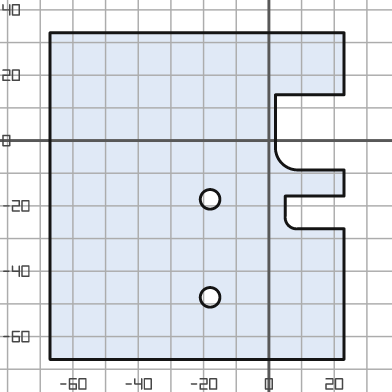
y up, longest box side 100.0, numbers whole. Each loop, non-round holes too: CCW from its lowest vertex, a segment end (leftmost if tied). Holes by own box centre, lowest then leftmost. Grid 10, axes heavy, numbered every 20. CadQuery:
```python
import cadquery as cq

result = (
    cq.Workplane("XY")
    .moveTo(-67.0, -67.0)
    .lineTo(23.0, -67.0)
    .lineTo(23.0, -27.0)
    .lineTo(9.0, -27.0)
    .threePointArc((6.0, -26.0), (5.0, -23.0))
    .lineTo(5.0, -17.0)
    .lineTo(23.0, -17.0)
    .lineTo(23.0, -9.0)
    .lineTo(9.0, -9.0)
    .threePointArc((4.0, -7.0), (2.0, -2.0))
    .lineTo(2.0, 14.0)
    .lineTo(23.0, 14.0)
    .lineTo(23.0, 33.0)
    .lineTo(-67.0, 33.0)
    .close()
    .moveTo(-18.0, -48.0)
    .circle(3.0)
    .moveTo(-18.0, -18.0)
    .circle(3.0)
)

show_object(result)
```